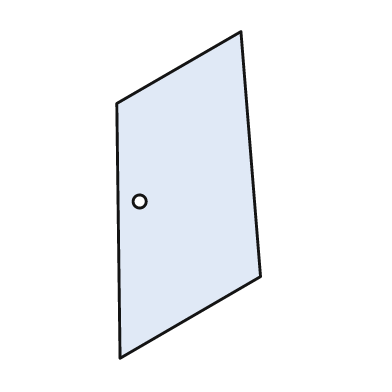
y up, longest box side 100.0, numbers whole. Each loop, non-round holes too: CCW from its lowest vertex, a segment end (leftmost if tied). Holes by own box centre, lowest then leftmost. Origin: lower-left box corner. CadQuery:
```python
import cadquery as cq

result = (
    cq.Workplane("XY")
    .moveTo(1.0, 0.0)
    .lineTo(44.0, 25.0)
    .lineTo(38.0, 100.0)
    .lineTo(0.0, 78.0)
    .close()
    .moveTo(7.0, 48.0)
    .circle(2.0)
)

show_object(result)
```